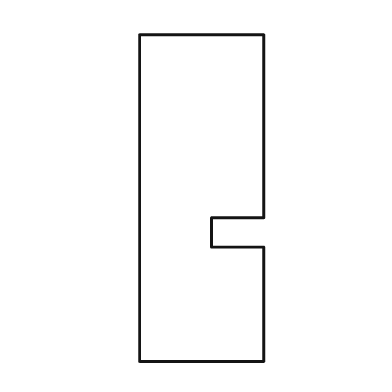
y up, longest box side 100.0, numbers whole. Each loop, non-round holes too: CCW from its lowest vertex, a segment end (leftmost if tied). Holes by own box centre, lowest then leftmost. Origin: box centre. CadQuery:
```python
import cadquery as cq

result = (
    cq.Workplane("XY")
    .moveTo(-19.0, -50.0)
    .lineTo(19.0, -50.0)
    .lineTo(19.0, -15.0)
    .lineTo(3.0, -15.0)
    .lineTo(3.0, -6.0)
    .lineTo(19.0, -6.0)
    .lineTo(19.0, 50.0)
    .lineTo(-19.0, 50.0)
    .close()
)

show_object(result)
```